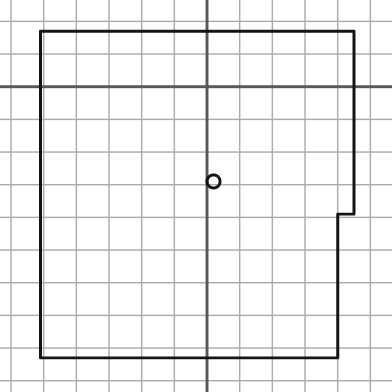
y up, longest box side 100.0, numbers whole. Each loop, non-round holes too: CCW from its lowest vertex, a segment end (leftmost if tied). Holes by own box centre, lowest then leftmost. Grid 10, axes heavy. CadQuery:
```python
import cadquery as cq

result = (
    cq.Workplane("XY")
    .moveTo(-51.0, -83.0)
    .lineTo(40.0, -83.0)
    .lineTo(40.0, -39.0)
    .lineTo(45.0, -39.0)
    .lineTo(45.0, 17.0)
    .lineTo(-51.0, 17.0)
    .close()
    .moveTo(2.0, -29.0)
    .circle(2.0)
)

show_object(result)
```